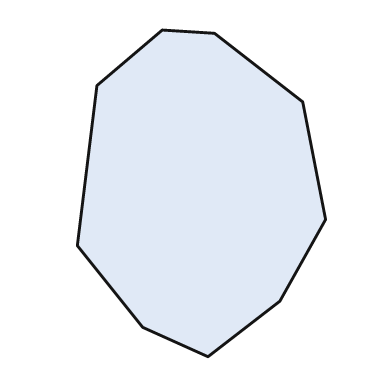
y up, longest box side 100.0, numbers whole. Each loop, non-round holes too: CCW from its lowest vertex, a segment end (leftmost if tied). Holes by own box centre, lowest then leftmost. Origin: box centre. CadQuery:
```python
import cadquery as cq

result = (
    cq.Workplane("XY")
    .moveTo(2.0, -50.0)
    .lineTo(24.0, -33.0)
    .lineTo(38.0, -8.0)
    .lineTo(31.0, 28.0)
    .lineTo(4.0, 49.0)
    .lineTo(-12.0, 50.0)
    .lineTo(-32.0, 33.0)
    .lineTo(-38.0, -16.0)
    .lineTo(-18.0, -41.0)
    .close()
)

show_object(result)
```